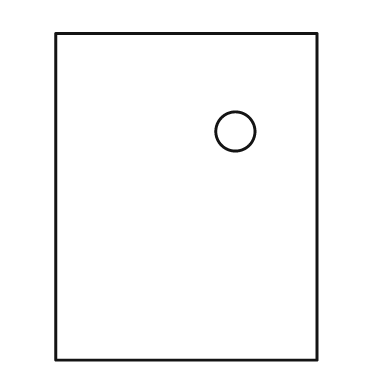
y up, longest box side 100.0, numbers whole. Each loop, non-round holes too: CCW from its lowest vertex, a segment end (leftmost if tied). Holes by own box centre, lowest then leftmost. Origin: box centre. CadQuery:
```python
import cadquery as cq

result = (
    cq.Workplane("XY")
    .moveTo(-40.0, -50.0)
    .lineTo(40.0, -50.0)
    .lineTo(40.0, 50.0)
    .lineTo(-40.0, 50.0)
    .close()
    .moveTo(15.0, 20.0)
    .circle(6.0)
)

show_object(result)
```